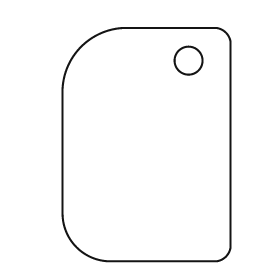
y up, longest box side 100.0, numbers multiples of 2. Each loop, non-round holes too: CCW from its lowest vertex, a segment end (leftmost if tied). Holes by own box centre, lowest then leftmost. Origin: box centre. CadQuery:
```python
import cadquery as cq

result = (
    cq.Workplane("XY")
    .moveTo(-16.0, -50.0)
    .lineTo(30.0, -50.0)
    .threePointArc((34.0, -48.0), (36.0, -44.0))
    .lineTo(36.0, 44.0)
    .threePointArc((34.0, 48.0), (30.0, 50.0))
    .lineTo(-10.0, 50.0)
    .threePointArc((-28.0, 42.0), (-36.0, 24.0))
    .lineTo(-36.0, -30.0)
    .threePointArc((-30.0, -44.0), (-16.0, -50.0))
    .close()
    .moveTo(18.0, 36.0)
    .circle(6.0)
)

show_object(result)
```